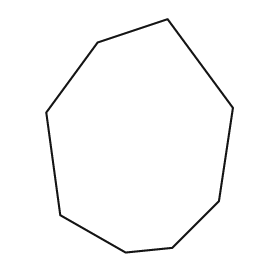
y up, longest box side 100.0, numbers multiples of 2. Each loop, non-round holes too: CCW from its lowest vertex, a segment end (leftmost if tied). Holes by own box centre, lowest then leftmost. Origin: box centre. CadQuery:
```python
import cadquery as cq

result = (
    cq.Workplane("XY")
    .moveTo(-6.0, -50.0)
    .lineTo(14.0, -48.0)
    .lineTo(34.0, -28.0)
    .lineTo(40.0, 12.0)
    .lineTo(12.0, 50.0)
    .lineTo(-18.0, 40.0)
    .lineTo(-40.0, 10.0)
    .lineTo(-34.0, -34.0)
    .close()
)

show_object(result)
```